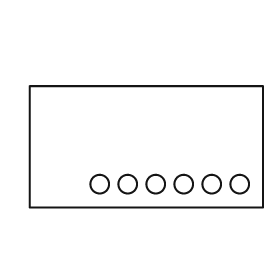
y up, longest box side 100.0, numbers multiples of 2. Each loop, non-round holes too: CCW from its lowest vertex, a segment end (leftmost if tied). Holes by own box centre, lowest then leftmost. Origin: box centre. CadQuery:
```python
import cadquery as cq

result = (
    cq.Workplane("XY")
    .moveTo(-50.0, -26.0)
    .lineTo(50.0, -26.0)
    .lineTo(50.0, 26.0)
    .lineTo(-50.0, 26.0)
    .close()
    .moveTo(-20.0, -16.0)
    .circle(4.0)
    .moveTo(-8.0, -16.0)
    .circle(4.0)
    .moveTo(4.0, -16.0)
    .circle(4.0)
    .moveTo(16.0, -16.0)
    .circle(4.0)
    .moveTo(28.0, -16.0)
    .circle(4.0)
    .moveTo(40.0, -16.0)
    .circle(4.0)
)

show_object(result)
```